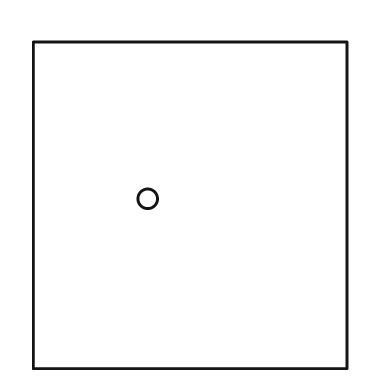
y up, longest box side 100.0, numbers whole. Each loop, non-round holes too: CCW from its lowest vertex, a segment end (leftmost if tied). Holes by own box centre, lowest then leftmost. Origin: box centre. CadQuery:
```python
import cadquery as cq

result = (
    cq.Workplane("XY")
    .moveTo(-48.0, -50.0)
    .lineTo(48.0, -50.0)
    .lineTo(48.0, 50.0)
    .lineTo(-48.0, 50.0)
    .close()
    .moveTo(-13.0, 2.0)
    .circle(3.0)
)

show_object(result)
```